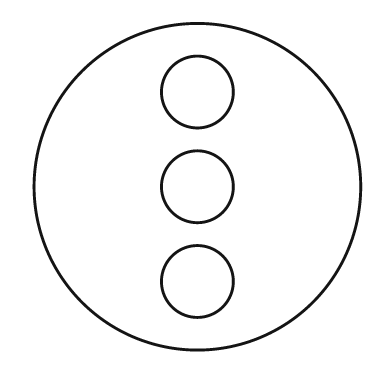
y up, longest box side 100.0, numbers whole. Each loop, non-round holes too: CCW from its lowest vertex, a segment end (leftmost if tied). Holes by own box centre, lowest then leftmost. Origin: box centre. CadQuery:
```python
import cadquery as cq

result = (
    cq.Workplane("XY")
    .moveTo(0.0, 0.0)
    .circle(50.0)
    .moveTo(0.0, -29.0)
    .circle(11.0)
    .moveTo(0.0, 0.0)
    .circle(11.0)
    .moveTo(0.0, 29.0)
    .circle(11.0)
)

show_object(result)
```